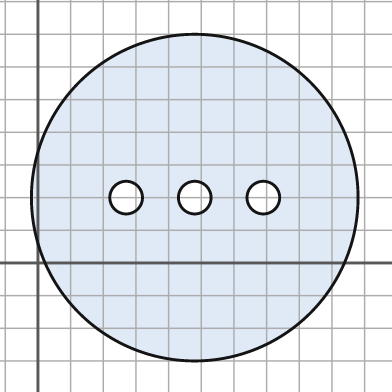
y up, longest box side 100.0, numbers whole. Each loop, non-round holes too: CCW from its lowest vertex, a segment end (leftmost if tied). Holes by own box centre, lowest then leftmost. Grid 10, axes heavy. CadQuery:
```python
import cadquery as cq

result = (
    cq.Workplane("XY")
    .moveTo(48.0, 20.0)
    .circle(50.0)
    .moveTo(27.0, 20.0)
    .circle(5.0)
    .moveTo(48.0, 20.0)
    .circle(5.0)
    .moveTo(69.0, 20.0)
    .circle(5.0)
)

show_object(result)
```